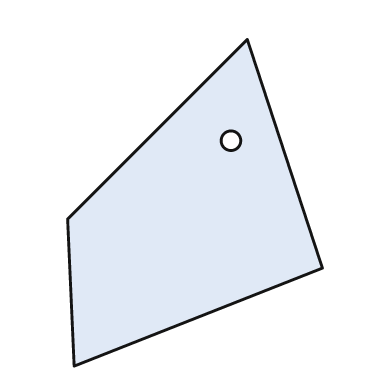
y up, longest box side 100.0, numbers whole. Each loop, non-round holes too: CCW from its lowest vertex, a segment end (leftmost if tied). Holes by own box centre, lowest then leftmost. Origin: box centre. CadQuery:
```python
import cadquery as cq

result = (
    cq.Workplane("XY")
    .moveTo(-37.0, -50.0)
    .lineTo(39.0, -20.0)
    .lineTo(16.0, 50.0)
    .lineTo(-39.0, -5.0)
    .close()
    .moveTo(11.0, 19.0)
    .circle(3.0)
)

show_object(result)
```